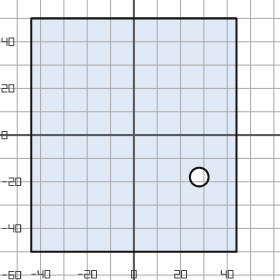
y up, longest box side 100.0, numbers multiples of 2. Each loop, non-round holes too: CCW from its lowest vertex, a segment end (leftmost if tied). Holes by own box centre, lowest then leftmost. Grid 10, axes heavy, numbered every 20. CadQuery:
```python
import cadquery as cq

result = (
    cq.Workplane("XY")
    .moveTo(-44.0, -50.0)
    .lineTo(44.0, -50.0)
    .lineTo(44.0, 50.0)
    .lineTo(-44.0, 50.0)
    .close()
    .moveTo(28.0, -18.0)
    .circle(4.0)
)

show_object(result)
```